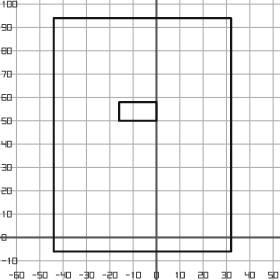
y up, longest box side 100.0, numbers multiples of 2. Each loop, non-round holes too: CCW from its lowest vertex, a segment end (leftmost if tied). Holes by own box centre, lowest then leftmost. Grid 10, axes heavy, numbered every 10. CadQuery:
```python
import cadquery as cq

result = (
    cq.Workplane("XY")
    .moveTo(-44.0, -6.0)
    .lineTo(32.0, -6.0)
    .lineTo(32.0, 94.0)
    .lineTo(-44.0, 94.0)
    .close()
    .moveTo(-16.0, 50.0)
    .lineTo(0.0, 50.0)
    .lineTo(0.0, 58.0)
    .lineTo(-16.0, 58.0)
    .close()
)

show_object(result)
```